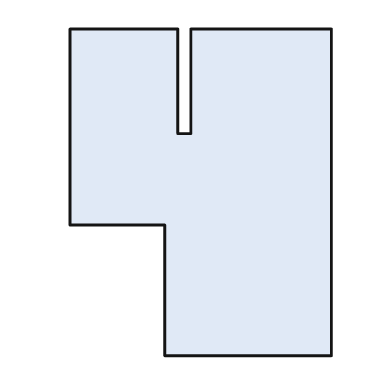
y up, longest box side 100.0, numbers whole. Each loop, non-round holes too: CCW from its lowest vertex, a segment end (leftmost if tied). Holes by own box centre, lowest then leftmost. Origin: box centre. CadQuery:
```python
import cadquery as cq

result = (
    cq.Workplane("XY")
    .moveTo(-11.0, -50.0)
    .lineTo(40.0, -50.0)
    .lineTo(40.0, 50.0)
    .lineTo(-3.0, 50.0)
    .lineTo(-3.0, 18.0)
    .lineTo(-7.0, 18.0)
    .lineTo(-7.0, 50.0)
    .lineTo(-40.0, 50.0)
    .lineTo(-40.0, -10.0)
    .lineTo(-11.0, -10.0)
    .close()
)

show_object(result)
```